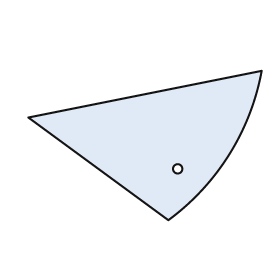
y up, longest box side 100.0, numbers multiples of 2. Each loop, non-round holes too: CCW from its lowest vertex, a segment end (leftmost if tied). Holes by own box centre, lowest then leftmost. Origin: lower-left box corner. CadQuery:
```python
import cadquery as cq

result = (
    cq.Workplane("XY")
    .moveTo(60.0, 0.0)
    .threePointArc((86.0, 28.0), (100.0, 64.0))
    .lineTo(0.0, 44.0)
    .close()
    .moveTo(64.0, 22.0)
    .circle(2.0)
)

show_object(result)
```